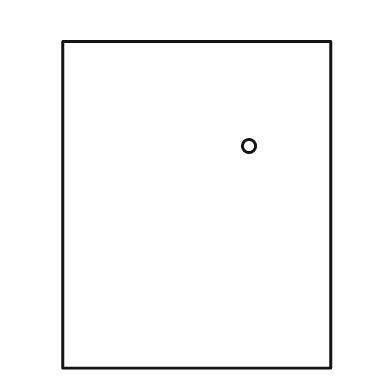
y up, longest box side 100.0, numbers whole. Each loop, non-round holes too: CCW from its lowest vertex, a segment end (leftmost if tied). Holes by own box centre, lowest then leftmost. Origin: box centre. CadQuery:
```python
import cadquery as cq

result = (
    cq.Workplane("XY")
    .moveTo(-41.0, -50.0)
    .lineTo(41.0, -50.0)
    .lineTo(41.0, 50.0)
    .lineTo(-41.0, 50.0)
    .close()
    .moveTo(16.0, 18.0)
    .circle(2.0)
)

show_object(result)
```